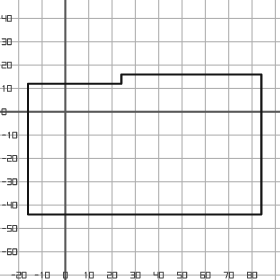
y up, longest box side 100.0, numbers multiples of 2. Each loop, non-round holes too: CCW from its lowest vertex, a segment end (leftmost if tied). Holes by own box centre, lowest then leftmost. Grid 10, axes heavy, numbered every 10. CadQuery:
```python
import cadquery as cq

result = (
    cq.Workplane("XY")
    .moveTo(-16.0, -44.0)
    .lineTo(84.0, -44.0)
    .lineTo(84.0, 16.0)
    .lineTo(24.0, 16.0)
    .lineTo(24.0, 12.0)
    .lineTo(-16.0, 12.0)
    .close()
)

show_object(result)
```